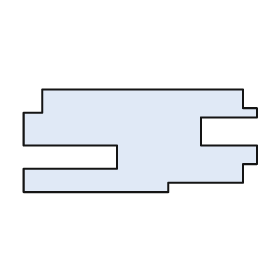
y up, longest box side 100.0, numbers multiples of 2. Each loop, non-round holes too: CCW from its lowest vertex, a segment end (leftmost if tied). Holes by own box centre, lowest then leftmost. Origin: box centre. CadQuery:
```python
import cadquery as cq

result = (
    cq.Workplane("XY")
    .moveTo(-50.0, -22.0)
    .lineTo(12.0, -22.0)
    .lineTo(12.0, -18.0)
    .lineTo(44.0, -18.0)
    .lineTo(44.0, -10.0)
    .lineTo(50.0, -10.0)
    .lineTo(50.0, -2.0)
    .lineTo(26.0, -2.0)
    .lineTo(26.0, 10.0)
    .lineTo(50.0, 10.0)
    .lineTo(50.0, 14.0)
    .lineTo(44.0, 14.0)
    .lineTo(44.0, 22.0)
    .lineTo(-42.0, 22.0)
    .lineTo(-42.0, 12.0)
    .lineTo(-50.0, 12.0)
    .lineTo(-50.0, -2.0)
    .lineTo(-10.0, -2.0)
    .lineTo(-10.0, -12.0)
    .lineTo(-50.0, -12.0)
    .close()
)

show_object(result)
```